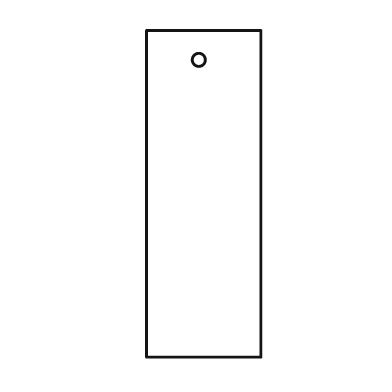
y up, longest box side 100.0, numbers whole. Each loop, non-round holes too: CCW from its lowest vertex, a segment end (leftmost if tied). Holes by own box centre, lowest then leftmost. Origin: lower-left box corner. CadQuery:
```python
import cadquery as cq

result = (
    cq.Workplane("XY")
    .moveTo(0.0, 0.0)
    .lineTo(35.0, 0.0)
    .lineTo(35.0, 100.0)
    .lineTo(0.0, 100.0)
    .close()
    .moveTo(16.0, 91.0)
    .circle(2.0)
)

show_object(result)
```